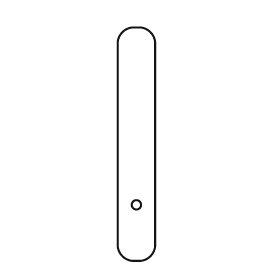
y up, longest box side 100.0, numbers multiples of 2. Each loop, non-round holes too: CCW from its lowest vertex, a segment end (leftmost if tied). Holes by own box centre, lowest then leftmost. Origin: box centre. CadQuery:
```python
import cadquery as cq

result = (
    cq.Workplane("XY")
    .moveTo(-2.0, -50.0)
    .lineTo(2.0, -50.0)
    .threePointArc((6.0, -48.0), (8.0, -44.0))
    .lineTo(8.0, 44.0)
    .threePointArc((6.0, 48.0), (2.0, 50.0))
    .lineTo(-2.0, 50.0)
    .threePointArc((-6.0, 48.0), (-8.0, 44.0))
    .lineTo(-8.0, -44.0)
    .threePointArc((-6.0, -48.0), (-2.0, -50.0))
    .close()
    .moveTo(0.0, -26.0)
    .circle(2.0)
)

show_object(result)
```